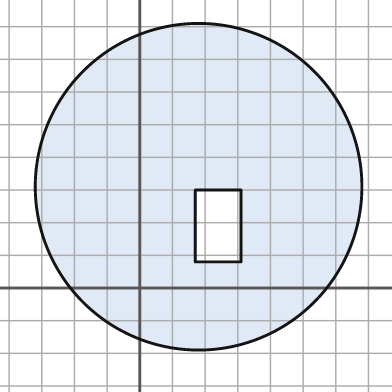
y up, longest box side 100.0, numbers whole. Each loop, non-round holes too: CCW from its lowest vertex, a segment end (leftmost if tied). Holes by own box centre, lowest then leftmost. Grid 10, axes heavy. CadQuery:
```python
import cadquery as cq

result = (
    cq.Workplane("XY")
    .moveTo(18.0, 31.0)
    .circle(50.0)
    .moveTo(17.0, 8.0)
    .lineTo(31.0, 8.0)
    .lineTo(31.0, 30.0)
    .lineTo(17.0, 30.0)
    .close()
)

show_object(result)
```